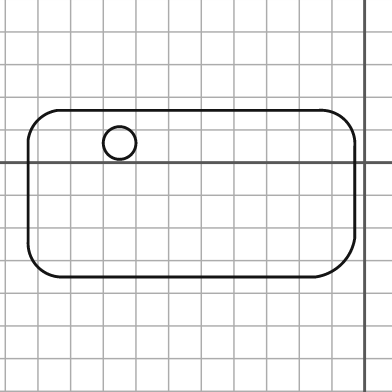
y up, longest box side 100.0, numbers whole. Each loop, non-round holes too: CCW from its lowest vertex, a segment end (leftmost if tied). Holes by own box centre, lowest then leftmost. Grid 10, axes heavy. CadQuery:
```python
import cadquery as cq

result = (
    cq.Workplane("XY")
    .moveTo(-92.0, -35.0)
    .lineTo(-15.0, -35.0)
    .threePointArc((-7.0, -31.0), (-3.0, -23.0))
    .lineTo(-3.0, 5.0)
    .threePointArc((-6.0, 13.0), (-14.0, 16.0))
    .lineTo(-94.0, 16.0)
    .threePointArc((-100.0, 13.0), (-103.0, 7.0))
    .lineTo(-103.0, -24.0)
    .threePointArc((-100.0, -32.0), (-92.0, -35.0))
    .close()
    .moveTo(-75.0, 6.0)
    .circle(5.0)
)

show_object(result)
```